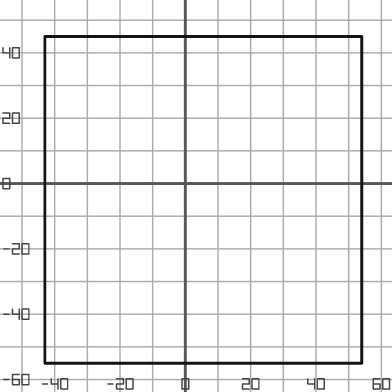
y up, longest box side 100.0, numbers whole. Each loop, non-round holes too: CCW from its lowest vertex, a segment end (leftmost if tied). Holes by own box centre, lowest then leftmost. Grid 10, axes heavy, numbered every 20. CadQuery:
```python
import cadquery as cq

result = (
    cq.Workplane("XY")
    .moveTo(-43.0, -55.0)
    .lineTo(54.0, -55.0)
    .lineTo(54.0, 45.0)
    .lineTo(-43.0, 45.0)
    .close()
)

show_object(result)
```